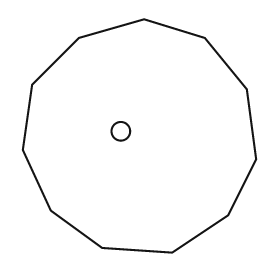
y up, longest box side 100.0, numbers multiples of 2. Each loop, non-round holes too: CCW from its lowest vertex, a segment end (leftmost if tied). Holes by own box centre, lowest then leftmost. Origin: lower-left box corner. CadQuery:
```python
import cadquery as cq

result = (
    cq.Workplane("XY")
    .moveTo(64.0, 0.0)
    .lineTo(88.0, 16.0)
    .lineTo(100.0, 40.0)
    .lineTo(96.0, 70.0)
    .lineTo(78.0, 92.0)
    .lineTo(52.0, 100.0)
    .lineTo(24.0, 92.0)
    .lineTo(4.0, 72.0)
    .lineTo(0.0, 44.0)
    .lineTo(12.0, 18.0)
    .lineTo(34.0, 2.0)
    .close()
    .moveTo(42.0, 52.0)
    .circle(4.0)
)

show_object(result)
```